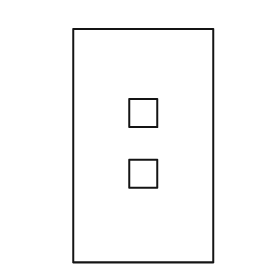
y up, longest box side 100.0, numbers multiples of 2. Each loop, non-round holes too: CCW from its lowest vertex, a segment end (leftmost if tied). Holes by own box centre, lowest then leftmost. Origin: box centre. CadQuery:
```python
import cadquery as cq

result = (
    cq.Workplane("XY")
    .moveTo(-30.0, -50.0)
    .lineTo(30.0, -50.0)
    .lineTo(30.0, 50.0)
    .lineTo(-30.0, 50.0)
    .close()
    .moveTo(-6.0, -18.0)
    .lineTo(6.0, -18.0)
    .lineTo(6.0, -6.0)
    .lineTo(-6.0, -6.0)
    .close()
    .moveTo(-6.0, 8.0)
    .lineTo(6.0, 8.0)
    .lineTo(6.0, 20.0)
    .lineTo(-6.0, 20.0)
    .close()
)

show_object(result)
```